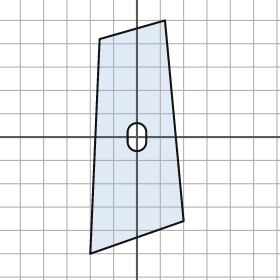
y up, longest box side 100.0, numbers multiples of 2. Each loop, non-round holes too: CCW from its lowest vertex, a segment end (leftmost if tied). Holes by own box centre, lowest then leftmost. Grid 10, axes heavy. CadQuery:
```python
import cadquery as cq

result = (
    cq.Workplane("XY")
    .moveTo(-20.0, -50.0)
    .lineTo(20.0, -36.0)
    .lineTo(12.0, 50.0)
    .lineTo(-16.0, 42.0)
    .close()
    .moveTo(-4.0, -2.0)
    .threePointArc((0.0, -6.0), (4.0, -2.0))
    .lineTo(4.0, 2.0)
    .threePointArc((0.0, 6.0), (-4.0, 2.0))
    .close()
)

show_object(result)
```